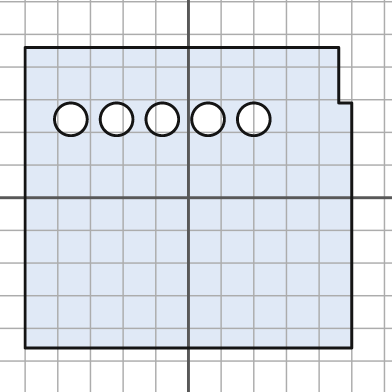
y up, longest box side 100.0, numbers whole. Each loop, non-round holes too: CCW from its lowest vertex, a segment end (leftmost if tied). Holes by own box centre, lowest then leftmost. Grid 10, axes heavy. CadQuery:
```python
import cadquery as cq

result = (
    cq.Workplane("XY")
    .moveTo(-50.0, -46.0)
    .lineTo(50.0, -46.0)
    .lineTo(50.0, 29.0)
    .lineTo(46.0, 29.0)
    .lineTo(46.0, 46.0)
    .lineTo(-50.0, 46.0)
    .close()
    .moveTo(-36.0, 24.0)
    .circle(5.0)
    .moveTo(-22.0, 24.0)
    .circle(5.0)
    .moveTo(-8.0, 24.0)
    .circle(5.0)
    .moveTo(6.0, 24.0)
    .circle(5.0)
    .moveTo(20.0, 24.0)
    .circle(5.0)
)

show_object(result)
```